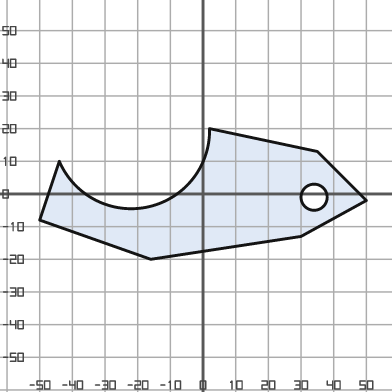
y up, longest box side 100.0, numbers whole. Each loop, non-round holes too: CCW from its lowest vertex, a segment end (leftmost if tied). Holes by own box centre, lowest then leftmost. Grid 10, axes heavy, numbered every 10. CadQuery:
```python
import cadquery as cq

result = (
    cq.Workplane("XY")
    .moveTo(-16.0, -20.0)
    .lineTo(30.0, -13.0)
    .lineTo(50.0, -2.0)
    .lineTo(35.0, 13.0)
    .lineTo(2.0, 20.0)
    .threePointArc((-17.0, -4.0), (-44.0, 10.0))
    .lineTo(-50.0, -8.0)
    .close()
    .moveTo(34.0, -1.0)
    .circle(4.0)
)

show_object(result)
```